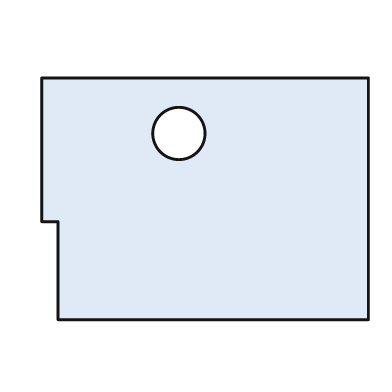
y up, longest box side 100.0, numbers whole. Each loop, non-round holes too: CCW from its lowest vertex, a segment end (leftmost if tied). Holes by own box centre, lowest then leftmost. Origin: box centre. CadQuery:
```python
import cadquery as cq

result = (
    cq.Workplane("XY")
    .moveTo(-45.0, -37.0)
    .lineTo(50.0, -37.0)
    .lineTo(50.0, 37.0)
    .lineTo(-50.0, 37.0)
    .lineTo(-50.0, -7.0)
    .lineTo(-45.0, -7.0)
    .close()
    .moveTo(-8.0, 20.0)
    .circle(8.0)
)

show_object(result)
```